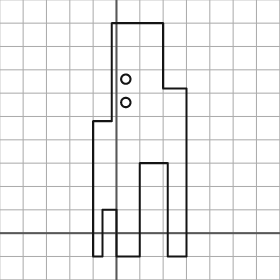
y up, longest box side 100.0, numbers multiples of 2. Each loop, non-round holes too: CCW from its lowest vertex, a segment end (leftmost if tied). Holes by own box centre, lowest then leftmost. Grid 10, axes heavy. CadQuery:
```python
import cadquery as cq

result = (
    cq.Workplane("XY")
    .moveTo(-10.0, -10.0)
    .lineTo(-6.0, -10.0)
    .lineTo(-6.0, 10.0)
    .lineTo(0.0, 10.0)
    .lineTo(0.0, -10.0)
    .lineTo(10.0, -10.0)
    .lineTo(10.0, 30.0)
    .lineTo(22.0, 30.0)
    .lineTo(22.0, -10.0)
    .lineTo(30.0, -10.0)
    .lineTo(30.0, 62.0)
    .lineTo(20.0, 62.0)
    .lineTo(20.0, 90.0)
    .lineTo(-2.0, 90.0)
    .lineTo(-2.0, 48.0)
    .lineTo(-10.0, 48.0)
    .close()
    .moveTo(4.0, 56.0)
    .circle(2.0)
    .moveTo(4.0, 66.0)
    .circle(2.0)
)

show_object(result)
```